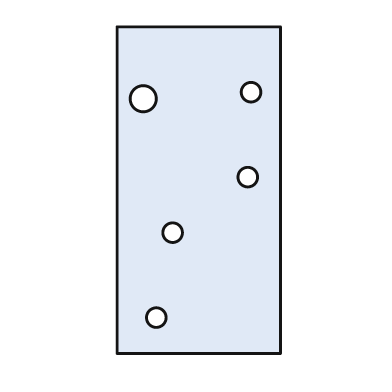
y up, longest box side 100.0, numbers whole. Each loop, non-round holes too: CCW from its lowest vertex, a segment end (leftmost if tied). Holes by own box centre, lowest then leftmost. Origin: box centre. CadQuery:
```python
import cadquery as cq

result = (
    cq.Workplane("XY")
    .moveTo(-25.0, -50.0)
    .lineTo(25.0, -50.0)
    .lineTo(25.0, 50.0)
    .lineTo(-25.0, 50.0)
    .close()
    .moveTo(-13.0, -39.0)
    .circle(3.0)
    .moveTo(-8.0, -13.0)
    .circle(3.0)
    .moveTo(15.0, 4.0)
    .circle(3.0)
    .moveTo(-17.0, 28.0)
    .circle(4.0)
    .moveTo(16.0, 30.0)
    .circle(3.0)
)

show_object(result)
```